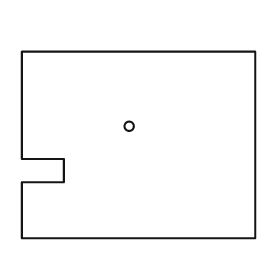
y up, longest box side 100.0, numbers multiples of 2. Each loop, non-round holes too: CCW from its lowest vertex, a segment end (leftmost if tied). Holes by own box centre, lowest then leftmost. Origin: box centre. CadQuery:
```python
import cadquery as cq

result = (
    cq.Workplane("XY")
    .moveTo(-50.0, -40.0)
    .lineTo(50.0, -40.0)
    .lineTo(50.0, 40.0)
    .lineTo(-50.0, 40.0)
    .lineTo(-50.0, -6.0)
    .lineTo(-32.0, -6.0)
    .lineTo(-32.0, -16.0)
    .lineTo(-50.0, -16.0)
    .close()
    .moveTo(-4.0, 8.0)
    .circle(2.0)
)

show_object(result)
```